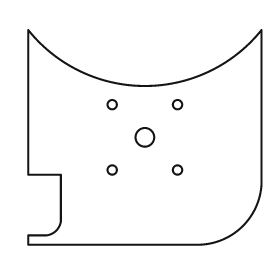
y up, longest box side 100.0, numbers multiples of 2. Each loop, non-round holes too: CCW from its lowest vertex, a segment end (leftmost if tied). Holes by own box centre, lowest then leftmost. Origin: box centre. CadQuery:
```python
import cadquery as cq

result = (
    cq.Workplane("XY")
    .moveTo(-50.0, -46.0)
    .lineTo(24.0, -46.0)
    .threePointArc((42.0, -38.0), (50.0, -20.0))
    .lineTo(50.0, 46.0)
    .threePointArc((0.0, 22.0), (-50.0, 46.0))
    .lineTo(-50.0, -16.0)
    .lineTo(-36.0, -16.0)
    .lineTo(-36.0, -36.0)
    .threePointArc((-38.0, -40.0), (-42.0, -42.0))
    .lineTo(-50.0, -42.0)
    .close()
    .moveTo(-14.0, -14.0)
    .circle(2.0)
    .moveTo(14.0, -14.0)
    .circle(2.0)
    .moveTo(0.0, 0.0)
    .circle(4.0)
    .moveTo(-14.0, 14.0)
    .circle(2.0)
    .moveTo(14.0, 14.0)
    .circle(2.0)
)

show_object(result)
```